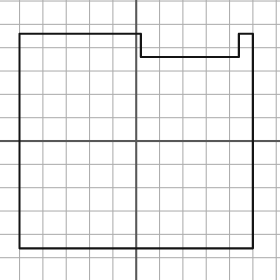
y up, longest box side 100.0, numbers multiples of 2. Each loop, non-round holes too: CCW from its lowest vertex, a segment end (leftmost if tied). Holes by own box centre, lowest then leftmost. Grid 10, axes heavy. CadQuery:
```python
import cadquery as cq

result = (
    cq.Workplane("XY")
    .moveTo(-50.0, -46.0)
    .lineTo(50.0, -46.0)
    .lineTo(50.0, 46.0)
    .lineTo(44.0, 46.0)
    .lineTo(44.0, 36.0)
    .lineTo(2.0, 36.0)
    .lineTo(2.0, 46.0)
    .lineTo(-50.0, 46.0)
    .close()
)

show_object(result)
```